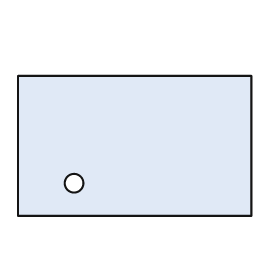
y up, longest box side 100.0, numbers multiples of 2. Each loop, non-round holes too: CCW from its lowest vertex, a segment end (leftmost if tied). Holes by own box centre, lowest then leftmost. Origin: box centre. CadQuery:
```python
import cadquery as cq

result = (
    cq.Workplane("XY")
    .moveTo(-50.0, -30.0)
    .lineTo(50.0, -30.0)
    .lineTo(50.0, 30.0)
    .lineTo(-50.0, 30.0)
    .close()
    .moveTo(-26.0, -16.0)
    .circle(4.0)
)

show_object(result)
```